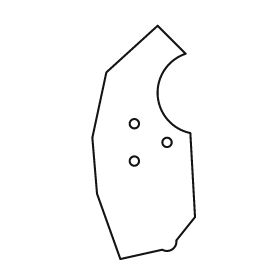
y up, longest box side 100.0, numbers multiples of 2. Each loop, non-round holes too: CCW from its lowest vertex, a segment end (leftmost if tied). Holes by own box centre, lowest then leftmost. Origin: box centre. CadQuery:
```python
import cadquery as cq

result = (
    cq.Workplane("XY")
    .moveTo(-10.0, -50.0)
    .lineTo(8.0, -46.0)
    .threePointArc((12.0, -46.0), (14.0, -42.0))
    .lineTo(22.0, -32.0)
    .lineTo(20.0, 4.0)
    .threePointArc((6.0, 20.0), (18.0, 38.0))
    .lineTo(6.0, 50.0)
    .lineTo(-16.0, 30.0)
    .lineTo(-22.0, 2.0)
    .lineTo(-20.0, -22.0)
    .close()
    .moveTo(-4.0, -8.0)
    .circle(2.0)
    .moveTo(10.0, 0.0)
    .circle(2.0)
    .moveTo(-4.0, 8.0)
    .circle(2.0)
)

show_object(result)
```